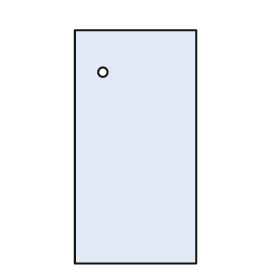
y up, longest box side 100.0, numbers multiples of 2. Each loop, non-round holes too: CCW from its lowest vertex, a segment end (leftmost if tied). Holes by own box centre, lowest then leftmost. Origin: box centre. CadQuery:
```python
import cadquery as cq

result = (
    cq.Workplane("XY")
    .moveTo(-26.0, -50.0)
    .lineTo(26.0, -50.0)
    .lineTo(26.0, 50.0)
    .lineTo(-26.0, 50.0)
    .close()
    .moveTo(-14.0, 32.0)
    .circle(2.0)
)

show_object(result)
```